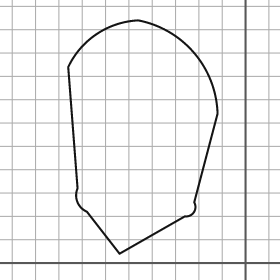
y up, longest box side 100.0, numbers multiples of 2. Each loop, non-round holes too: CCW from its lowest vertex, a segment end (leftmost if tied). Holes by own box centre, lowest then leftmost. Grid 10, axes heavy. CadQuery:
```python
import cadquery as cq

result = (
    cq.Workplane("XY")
    .moveTo(-54.0, 4.0)
    .lineTo(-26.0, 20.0)
    .threePointArc((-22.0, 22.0), (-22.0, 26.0))
    .lineTo(-12.0, 64.0)
    .threePointArc((-22.0, 90.0), (-46.0, 104.0))
    .threePointArc((-64.0, 98.0), (-76.0, 84.0))
    .lineTo(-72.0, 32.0)
    .threePointArc((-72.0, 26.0), (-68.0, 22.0))
    .close()
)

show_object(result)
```